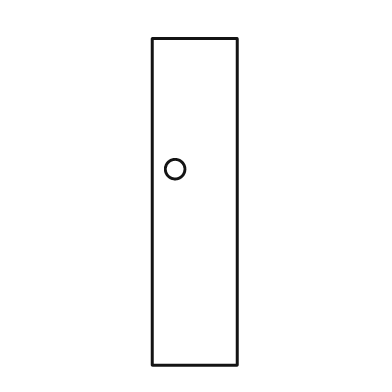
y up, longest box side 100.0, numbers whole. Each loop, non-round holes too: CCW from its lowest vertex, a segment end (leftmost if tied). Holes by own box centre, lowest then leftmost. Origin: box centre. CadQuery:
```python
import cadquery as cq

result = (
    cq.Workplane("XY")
    .moveTo(-13.0, -50.0)
    .lineTo(13.0, -50.0)
    .lineTo(13.0, 50.0)
    .lineTo(-13.0, 50.0)
    .close()
    .moveTo(-6.0, 10.0)
    .circle(3.0)
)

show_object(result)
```